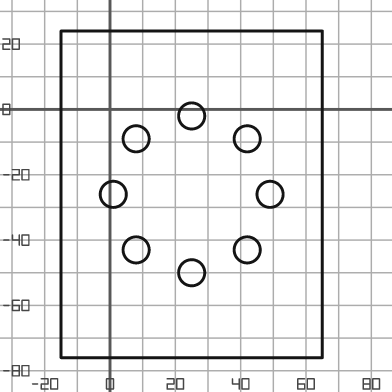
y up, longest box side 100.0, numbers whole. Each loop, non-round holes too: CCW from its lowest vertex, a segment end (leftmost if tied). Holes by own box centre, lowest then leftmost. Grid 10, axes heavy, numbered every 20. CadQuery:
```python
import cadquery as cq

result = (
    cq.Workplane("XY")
    .moveTo(-15.0, -76.0)
    .lineTo(65.0, -76.0)
    .lineTo(65.0, 24.0)
    .lineTo(-15.0, 24.0)
    .close()
    .moveTo(25.0, -50.0)
    .circle(4.0)
    .moveTo(8.0, -43.0)
    .circle(4.0)
    .moveTo(42.0, -43.0)
    .circle(4.0)
    .moveTo(1.0, -26.0)
    .circle(4.0)
    .moveTo(49.0, -26.0)
    .circle(4.0)
    .moveTo(8.0, -9.0)
    .circle(4.0)
    .moveTo(42.0, -9.0)
    .circle(4.0)
    .moveTo(25.0, -2.0)
    .circle(4.0)
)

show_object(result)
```